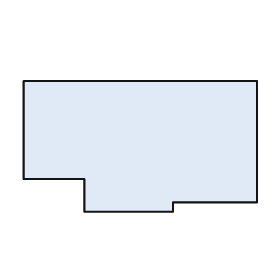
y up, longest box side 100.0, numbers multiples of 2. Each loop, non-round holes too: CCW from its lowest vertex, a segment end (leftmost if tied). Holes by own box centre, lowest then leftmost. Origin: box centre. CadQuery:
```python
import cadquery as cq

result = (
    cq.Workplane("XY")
    .moveTo(-24.0, -28.0)
    .lineTo(14.0, -28.0)
    .lineTo(14.0, -24.0)
    .lineTo(50.0, -24.0)
    .lineTo(50.0, 28.0)
    .lineTo(-50.0, 28.0)
    .lineTo(-50.0, -14.0)
    .lineTo(-24.0, -14.0)
    .close()
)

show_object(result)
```